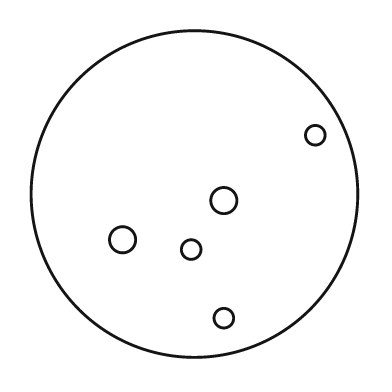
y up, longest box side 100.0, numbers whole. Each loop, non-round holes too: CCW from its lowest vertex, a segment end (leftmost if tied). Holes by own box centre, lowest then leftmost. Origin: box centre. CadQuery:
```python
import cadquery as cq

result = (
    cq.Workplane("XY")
    .moveTo(0.0, 0.0)
    .circle(50.0)
    .moveTo(9.0, -38.0)
    .circle(3.0)
    .moveTo(-1.0, -17.0)
    .circle(3.0)
    .moveTo(-22.0, -14.0)
    .circle(4.0)
    .moveTo(9.0, -2.0)
    .circle(4.0)
    .moveTo(37.0, 18.0)
    .circle(3.0)
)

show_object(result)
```